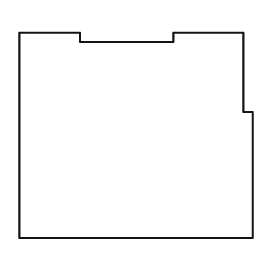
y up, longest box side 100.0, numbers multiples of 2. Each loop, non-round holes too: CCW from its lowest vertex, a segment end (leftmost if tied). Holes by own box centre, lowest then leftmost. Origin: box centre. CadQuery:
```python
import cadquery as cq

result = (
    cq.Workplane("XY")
    .moveTo(-50.0, -44.0)
    .lineTo(50.0, -44.0)
    .lineTo(50.0, 10.0)
    .lineTo(46.0, 10.0)
    .lineTo(46.0, 44.0)
    .lineTo(16.0, 44.0)
    .lineTo(16.0, 40.0)
    .lineTo(-24.0, 40.0)
    .lineTo(-24.0, 44.0)
    .lineTo(-50.0, 44.0)
    .close()
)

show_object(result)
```